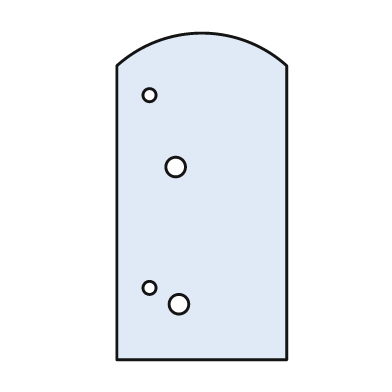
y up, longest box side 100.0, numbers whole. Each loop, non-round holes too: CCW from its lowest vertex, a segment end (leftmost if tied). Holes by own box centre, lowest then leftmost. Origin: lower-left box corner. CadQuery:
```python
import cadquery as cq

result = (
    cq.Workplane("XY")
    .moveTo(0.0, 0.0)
    .lineTo(52.0, 0.0)
    .lineTo(52.0, 90.0)
    .threePointArc((26.0, 100.0), (0.0, 90.0))
    .close()
    .moveTo(19.0, 17.0)
    .circle(3.0)
    .moveTo(10.0, 22.0)
    .circle(2.0)
    .moveTo(18.0, 59.0)
    .circle(3.0)
    .moveTo(10.0, 81.0)
    .circle(2.0)
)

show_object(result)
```